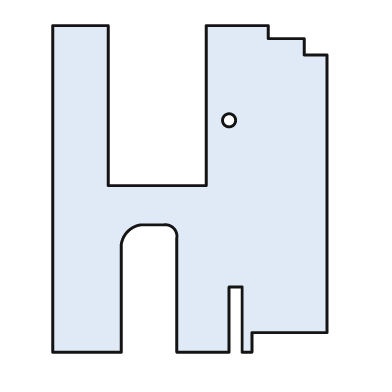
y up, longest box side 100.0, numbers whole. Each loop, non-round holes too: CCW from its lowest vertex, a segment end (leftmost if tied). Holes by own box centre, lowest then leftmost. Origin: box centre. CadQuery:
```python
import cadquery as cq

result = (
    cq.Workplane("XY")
    .moveTo(-42.0, -50.0)
    .lineTo(-21.0, -50.0)
    .lineTo(-21.0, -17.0)
    .threePointArc((-19.0, -13.0), (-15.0, -11.0))
    .lineTo(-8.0, -11.0)
    .threePointArc((-5.0, -12.0), (-4.0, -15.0))
    .lineTo(-4.0, -50.0)
    .lineTo(12.0, -50.0)
    .lineTo(12.0, -30.0)
    .lineTo(16.0, -30.0)
    .lineTo(16.0, -50.0)
    .lineTo(19.0, -50.0)
    .lineTo(19.0, -44.0)
    .lineTo(42.0, -44.0)
    .lineTo(42.0, 41.0)
    .lineTo(35.0, 41.0)
    .lineTo(35.0, 46.0)
    .lineTo(24.0, 46.0)
    .lineTo(24.0, 50.0)
    .lineTo(5.0, 50.0)
    .lineTo(5.0, 1.0)
    .lineTo(-25.0, 1.0)
    .lineTo(-25.0, 50.0)
    .lineTo(-42.0, 50.0)
    .close()
    .moveTo(12.0, 21.0)
    .circle(2.0)
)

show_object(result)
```